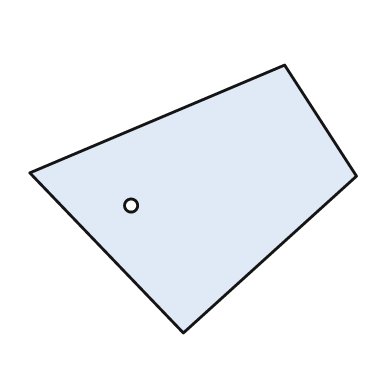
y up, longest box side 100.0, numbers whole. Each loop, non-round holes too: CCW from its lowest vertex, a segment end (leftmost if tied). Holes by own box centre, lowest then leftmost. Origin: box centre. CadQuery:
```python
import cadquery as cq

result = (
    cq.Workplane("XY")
    .moveTo(-3.0, -41.0)
    .lineTo(50.0, 7.0)
    .lineTo(28.0, 41.0)
    .lineTo(-50.0, 8.0)
    .close()
    .moveTo(-19.0, -2.0)
    .circle(2.0)
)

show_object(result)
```